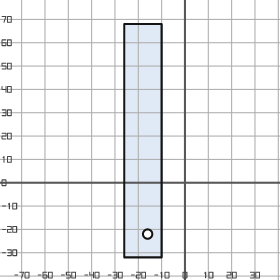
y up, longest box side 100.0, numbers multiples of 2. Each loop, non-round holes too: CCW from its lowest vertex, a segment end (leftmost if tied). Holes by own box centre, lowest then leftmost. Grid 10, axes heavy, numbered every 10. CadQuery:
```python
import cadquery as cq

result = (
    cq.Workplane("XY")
    .moveTo(-26.0, -32.0)
    .lineTo(-10.0, -32.0)
    .lineTo(-10.0, 68.0)
    .lineTo(-26.0, 68.0)
    .close()
    .moveTo(-16.0, -22.0)
    .circle(2.0)
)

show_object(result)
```